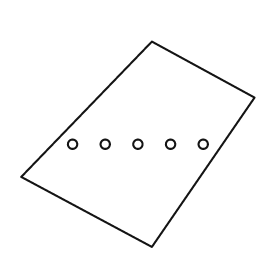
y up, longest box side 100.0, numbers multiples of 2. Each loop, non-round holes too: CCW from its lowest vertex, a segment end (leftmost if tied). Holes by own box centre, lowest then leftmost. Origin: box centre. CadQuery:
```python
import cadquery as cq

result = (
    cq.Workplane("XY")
    .moveTo(6.0, -44.0)
    .lineTo(50.0, 20.0)
    .lineTo(6.0, 44.0)
    .lineTo(-50.0, -14.0)
    .close()
    .moveTo(-28.0, 0.0)
    .circle(2.0)
    .moveTo(-14.0, 0.0)
    .circle(2.0)
    .moveTo(0.0, 0.0)
    .circle(2.0)
    .moveTo(14.0, 0.0)
    .circle(2.0)
    .moveTo(28.0, 0.0)
    .circle(2.0)
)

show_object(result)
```